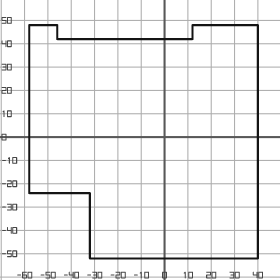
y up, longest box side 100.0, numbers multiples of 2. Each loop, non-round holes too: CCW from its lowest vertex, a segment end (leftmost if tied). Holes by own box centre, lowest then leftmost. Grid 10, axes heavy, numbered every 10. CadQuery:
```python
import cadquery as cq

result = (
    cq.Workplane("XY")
    .moveTo(-32.0, -52.0)
    .lineTo(40.0, -52.0)
    .lineTo(40.0, 48.0)
    .lineTo(12.0, 48.0)
    .lineTo(12.0, 42.0)
    .lineTo(-46.0, 42.0)
    .lineTo(-46.0, 48.0)
    .lineTo(-58.0, 48.0)
    .lineTo(-58.0, -24.0)
    .lineTo(-32.0, -24.0)
    .close()
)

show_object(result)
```